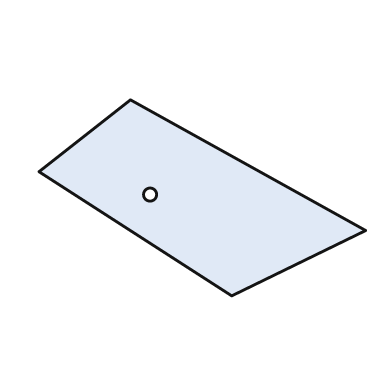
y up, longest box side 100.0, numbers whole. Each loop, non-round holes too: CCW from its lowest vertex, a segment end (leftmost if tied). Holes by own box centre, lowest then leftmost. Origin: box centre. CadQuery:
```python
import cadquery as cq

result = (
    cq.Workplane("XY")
    .moveTo(9.0, -30.0)
    .lineTo(50.0, -10.0)
    .lineTo(-22.0, 30.0)
    .lineTo(-50.0, 8.0)
    .close()
    .moveTo(-16.0, 1.0)
    .circle(2.0)
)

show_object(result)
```